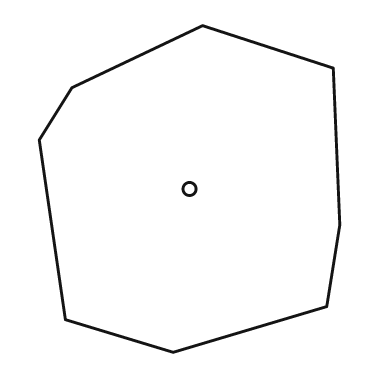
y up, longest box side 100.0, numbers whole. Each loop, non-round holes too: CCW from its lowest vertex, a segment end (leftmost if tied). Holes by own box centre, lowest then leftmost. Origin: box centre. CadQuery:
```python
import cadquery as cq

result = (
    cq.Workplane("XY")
    .moveTo(-5.0, -50.0)
    .lineTo(42.0, -36.0)
    .lineTo(46.0, -11.0)
    .lineTo(44.0, 37.0)
    .lineTo(4.0, 50.0)
    .lineTo(-36.0, 31.0)
    .lineTo(-46.0, 15.0)
    .lineTo(-38.0, -40.0)
    .close()
    .moveTo(0.0, 0.0)
    .circle(2.0)
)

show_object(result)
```